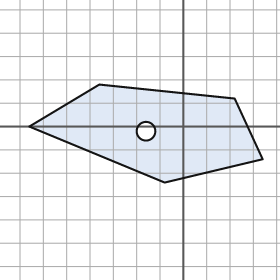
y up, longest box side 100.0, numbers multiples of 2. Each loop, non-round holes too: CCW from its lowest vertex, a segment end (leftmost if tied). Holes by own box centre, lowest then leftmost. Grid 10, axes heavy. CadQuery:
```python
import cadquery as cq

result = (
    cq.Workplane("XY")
    .moveTo(-8.0, -24.0)
    .lineTo(34.0, -14.0)
    .lineTo(22.0, 12.0)
    .lineTo(-36.0, 18.0)
    .lineTo(-66.0, 0.0)
    .close()
    .moveTo(-16.0, -2.0)
    .circle(4.0)
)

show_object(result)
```